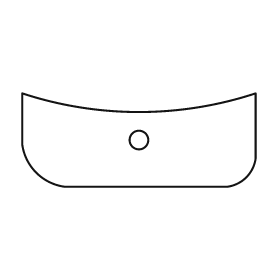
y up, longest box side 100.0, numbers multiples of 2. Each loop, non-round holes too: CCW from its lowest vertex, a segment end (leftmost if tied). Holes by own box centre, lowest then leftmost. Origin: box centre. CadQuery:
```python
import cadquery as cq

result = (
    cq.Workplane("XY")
    .moveTo(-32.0, -20.0)
    .lineTo(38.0, -20.0)
    .threePointArc((46.0, -16.0), (50.0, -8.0))
    .lineTo(50.0, 20.0)
    .threePointArc((0.0, 12.0), (-50.0, 20.0))
    .lineTo(-50.0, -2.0)
    .threePointArc((-44.0, -14.0), (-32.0, -20.0))
    .close()
    .moveTo(0.0, 0.0)
    .circle(4.0)
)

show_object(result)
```